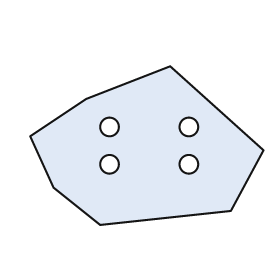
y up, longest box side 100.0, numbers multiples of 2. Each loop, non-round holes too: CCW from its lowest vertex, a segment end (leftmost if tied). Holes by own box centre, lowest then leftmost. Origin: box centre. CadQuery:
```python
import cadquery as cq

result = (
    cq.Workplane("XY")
    .moveTo(-20.0, -34.0)
    .lineTo(36.0, -28.0)
    .lineTo(50.0, -2.0)
    .lineTo(10.0, 34.0)
    .lineTo(-26.0, 20.0)
    .lineTo(-50.0, 4.0)
    .lineTo(-40.0, -18.0)
    .close()
    .moveTo(-16.0, -8.0)
    .circle(4.0)
    .moveTo(18.0, -8.0)
    .circle(4.0)
    .moveTo(-16.0, 8.0)
    .circle(4.0)
    .moveTo(18.0, 8.0)
    .circle(4.0)
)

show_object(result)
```